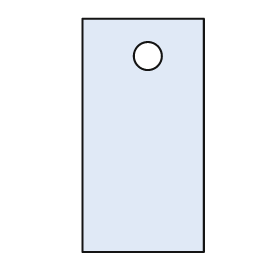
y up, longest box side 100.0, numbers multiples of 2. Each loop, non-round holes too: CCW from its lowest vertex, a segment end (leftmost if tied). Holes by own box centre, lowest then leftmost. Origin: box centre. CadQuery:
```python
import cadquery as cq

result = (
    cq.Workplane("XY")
    .moveTo(-26.0, -50.0)
    .lineTo(26.0, -50.0)
    .lineTo(26.0, 50.0)
    .lineTo(-26.0, 50.0)
    .close()
    .moveTo(2.0, 34.0)
    .circle(6.0)
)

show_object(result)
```